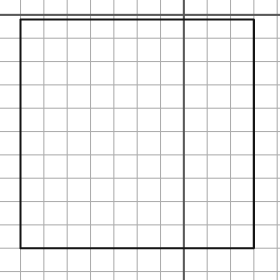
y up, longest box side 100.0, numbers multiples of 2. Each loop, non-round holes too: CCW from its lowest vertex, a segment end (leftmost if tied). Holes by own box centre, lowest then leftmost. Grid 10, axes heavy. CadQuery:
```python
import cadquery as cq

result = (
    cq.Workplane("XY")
    .moveTo(-70.0, -100.0)
    .lineTo(30.0, -100.0)
    .lineTo(30.0, -2.0)
    .lineTo(-70.0, -2.0)
    .close()
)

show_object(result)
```